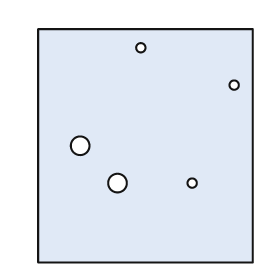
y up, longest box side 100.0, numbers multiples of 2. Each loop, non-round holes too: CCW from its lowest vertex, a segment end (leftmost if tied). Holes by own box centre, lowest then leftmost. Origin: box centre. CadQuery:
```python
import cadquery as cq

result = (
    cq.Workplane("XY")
    .moveTo(-46.0, -50.0)
    .lineTo(46.0, -50.0)
    .lineTo(46.0, 50.0)
    .lineTo(-46.0, 50.0)
    .close()
    .moveTo(-12.0, -16.0)
    .circle(4.0)
    .moveTo(20.0, -16.0)
    .circle(2.0)
    .moveTo(-28.0, 0.0)
    .circle(4.0)
    .moveTo(38.0, 26.0)
    .circle(2.0)
    .moveTo(-2.0, 42.0)
    .circle(2.0)
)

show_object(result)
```